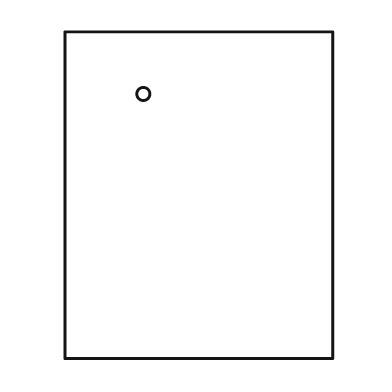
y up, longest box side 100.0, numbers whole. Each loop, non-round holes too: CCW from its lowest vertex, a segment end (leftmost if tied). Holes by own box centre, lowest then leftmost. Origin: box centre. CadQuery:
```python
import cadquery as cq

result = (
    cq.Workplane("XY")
    .moveTo(-41.0, -50.0)
    .lineTo(41.0, -50.0)
    .lineTo(41.0, 50.0)
    .lineTo(-41.0, 50.0)
    .close()
    .moveTo(-17.0, 31.0)
    .circle(2.0)
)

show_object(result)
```